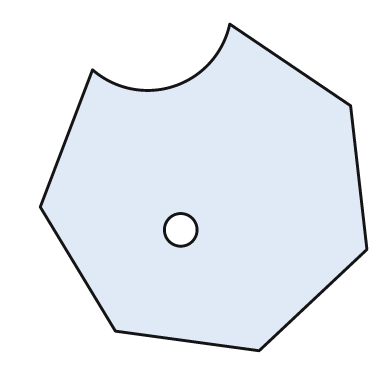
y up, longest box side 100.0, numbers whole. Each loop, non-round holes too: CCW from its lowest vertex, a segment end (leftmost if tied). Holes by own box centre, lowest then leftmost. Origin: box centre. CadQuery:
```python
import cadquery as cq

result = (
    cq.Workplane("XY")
    .moveTo(17.0, -50.0)
    .lineTo(50.0, -19.0)
    .lineTo(45.0, 25.0)
    .lineTo(8.0, 50.0)
    .threePointArc((-9.0, 31.0), (-34.0, 36.0))
    .lineTo(-50.0, -6.0)
    .lineTo(-27.0, -44.0)
    .close()
    .moveTo(-7.0, -13.0)
    .circle(5.0)
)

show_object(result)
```